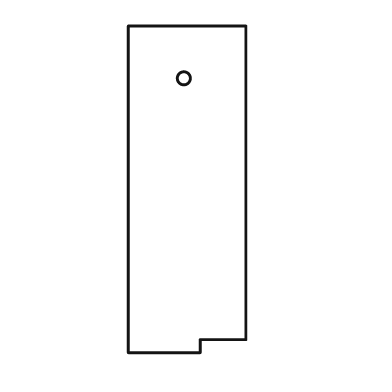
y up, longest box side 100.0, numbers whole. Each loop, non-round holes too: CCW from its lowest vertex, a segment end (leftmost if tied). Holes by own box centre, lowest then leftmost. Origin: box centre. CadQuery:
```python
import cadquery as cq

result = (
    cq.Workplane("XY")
    .moveTo(-18.0, -50.0)
    .lineTo(4.0, -50.0)
    .lineTo(4.0, -46.0)
    .lineTo(18.0, -46.0)
    .lineTo(18.0, 50.0)
    .lineTo(-18.0, 50.0)
    .close()
    .moveTo(-1.0, 34.0)
    .circle(2.0)
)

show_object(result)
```